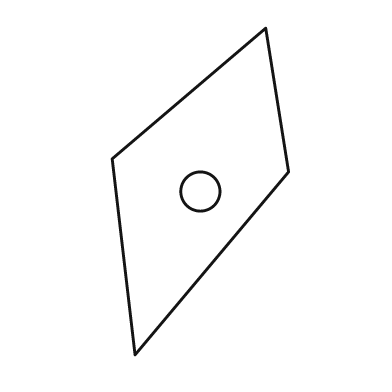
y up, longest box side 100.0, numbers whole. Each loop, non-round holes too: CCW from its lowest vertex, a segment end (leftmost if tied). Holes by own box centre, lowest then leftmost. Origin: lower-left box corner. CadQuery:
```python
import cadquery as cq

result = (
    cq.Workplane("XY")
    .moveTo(7.0, 0.0)
    .lineTo(54.0, 56.0)
    .lineTo(47.0, 100.0)
    .lineTo(0.0, 60.0)
    .close()
    .moveTo(27.0, 50.0)
    .circle(6.0)
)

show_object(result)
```